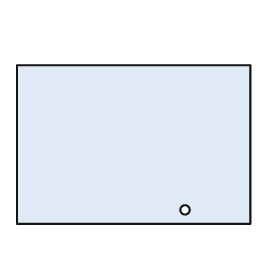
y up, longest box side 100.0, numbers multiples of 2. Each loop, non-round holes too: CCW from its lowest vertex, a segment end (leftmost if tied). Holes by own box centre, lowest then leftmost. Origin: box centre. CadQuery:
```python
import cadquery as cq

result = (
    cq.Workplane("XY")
    .moveTo(-50.0, -34.0)
    .lineTo(50.0, -34.0)
    .lineTo(50.0, 34.0)
    .lineTo(-50.0, 34.0)
    .close()
    .moveTo(22.0, -28.0)
    .circle(2.0)
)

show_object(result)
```